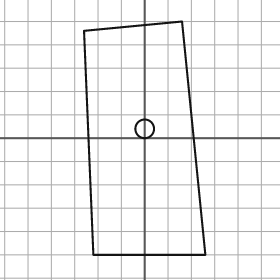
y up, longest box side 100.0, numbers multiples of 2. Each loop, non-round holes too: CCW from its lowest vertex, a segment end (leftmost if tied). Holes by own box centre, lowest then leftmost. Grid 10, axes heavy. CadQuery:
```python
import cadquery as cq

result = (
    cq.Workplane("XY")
    .moveTo(-22.0, -50.0)
    .lineTo(26.0, -50.0)
    .lineTo(16.0, 50.0)
    .lineTo(-26.0, 46.0)
    .close()
    .moveTo(0.0, 4.0)
    .circle(4.0)
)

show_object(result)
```